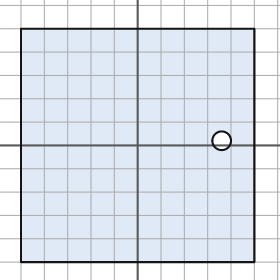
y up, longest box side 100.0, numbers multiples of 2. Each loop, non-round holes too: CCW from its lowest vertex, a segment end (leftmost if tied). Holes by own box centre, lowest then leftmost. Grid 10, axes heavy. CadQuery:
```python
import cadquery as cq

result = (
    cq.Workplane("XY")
    .moveTo(-50.0, -50.0)
    .lineTo(50.0, -50.0)
    .lineTo(50.0, 50.0)
    .lineTo(-50.0, 50.0)
    .close()
    .moveTo(36.0, 2.0)
    .circle(4.0)
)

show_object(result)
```